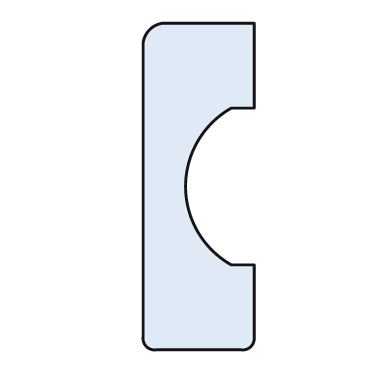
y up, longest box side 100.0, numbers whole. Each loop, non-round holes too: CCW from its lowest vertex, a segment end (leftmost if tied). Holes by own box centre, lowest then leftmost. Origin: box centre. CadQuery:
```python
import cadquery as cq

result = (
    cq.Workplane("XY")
    .moveTo(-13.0, -50.0)
    .lineTo(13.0, -50.0)
    .threePointArc((16.0, -49.0), (17.0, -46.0))
    .lineTo(17.0, -24.0)
    .lineTo(10.0, -24.0)
    .threePointArc((-4.0, 0.0), (10.0, 24.0))
    .lineTo(17.0, 24.0)
    .lineTo(17.0, 50.0)
    .lineTo(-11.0, 50.0)
    .threePointArc((-15.0, 48.0), (-17.0, 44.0))
    .lineTo(-17.0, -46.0)
    .threePointArc((-16.0, -49.0), (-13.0, -50.0))
    .close()
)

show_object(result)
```